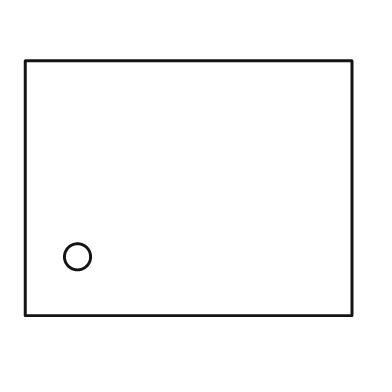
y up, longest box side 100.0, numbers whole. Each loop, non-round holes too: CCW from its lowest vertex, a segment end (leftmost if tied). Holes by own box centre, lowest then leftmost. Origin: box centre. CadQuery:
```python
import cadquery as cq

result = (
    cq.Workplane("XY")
    .moveTo(-50.0, -39.0)
    .lineTo(50.0, -39.0)
    .lineTo(50.0, 39.0)
    .lineTo(-50.0, 39.0)
    .close()
    .moveTo(-34.0, -21.0)
    .circle(4.0)
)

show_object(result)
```